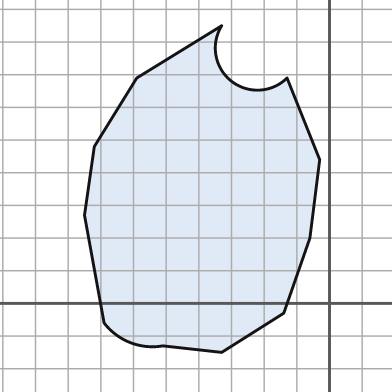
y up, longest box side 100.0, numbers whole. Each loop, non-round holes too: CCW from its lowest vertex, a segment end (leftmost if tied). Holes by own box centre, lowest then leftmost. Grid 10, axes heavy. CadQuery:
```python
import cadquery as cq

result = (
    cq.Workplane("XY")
    .moveTo(-33.0, -15.0)
    .lineTo(-14.0, -3.0)
    .lineTo(-6.0, 20.0)
    .lineTo(-3.0, 44.0)
    .lineTo(-13.0, 69.0)
    .threePointArc((-30.0, 68.0), (-33.0, 85.0))
    .lineTo(-59.0, 69.0)
    .lineTo(-72.0, 48.0)
    .lineTo(-75.0, 27.0)
    .lineTo(-69.0, -6.0)
    .threePointArc((-61.0, -12.0), (-51.0, -13.0))
    .close()
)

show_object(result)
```